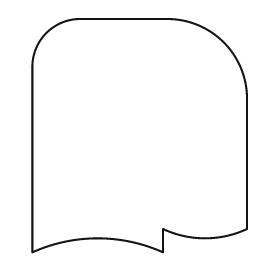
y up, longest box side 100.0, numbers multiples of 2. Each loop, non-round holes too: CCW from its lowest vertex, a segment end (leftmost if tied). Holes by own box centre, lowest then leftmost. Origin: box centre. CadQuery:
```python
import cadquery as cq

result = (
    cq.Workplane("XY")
    .moveTo(-46.0, -50.0)
    .threePointArc((-18.0, -44.0), (10.0, -50.0))
    .lineTo(10.0, -40.0)
    .threePointArc((28.0, -44.0), (46.0, -40.0))
    .lineTo(46.0, 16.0)
    .threePointArc((36.0, 40.0), (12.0, 50.0))
    .lineTo(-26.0, 50.0)
    .threePointArc((-40.0, 44.0), (-46.0, 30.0))
    .close()
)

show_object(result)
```